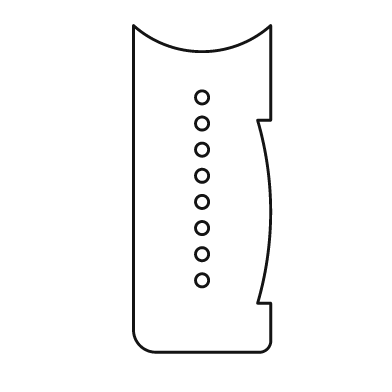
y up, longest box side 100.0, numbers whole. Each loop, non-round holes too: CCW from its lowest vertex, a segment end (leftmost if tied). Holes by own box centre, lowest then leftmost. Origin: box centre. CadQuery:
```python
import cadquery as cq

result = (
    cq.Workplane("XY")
    .moveTo(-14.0, -50.0)
    .lineTo(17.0, -50.0)
    .threePointArc((20.0, -49.0), (21.0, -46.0))
    .lineTo(21.0, -35.0)
    .lineTo(17.0, -35.0)
    .threePointArc((21.0, -7.0), (17.0, 21.0))
    .lineTo(21.0, 21.0)
    .lineTo(21.0, 50.0)
    .threePointArc((0.0, 42.0), (-21.0, 50.0))
    .lineTo(-21.0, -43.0)
    .threePointArc((-19.0, -48.0), (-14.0, -50.0))
    .close()
    .moveTo(0.0, -28.0)
    .circle(2.0)
    .moveTo(0.0, -20.0)
    .circle(2.0)
    .moveTo(0.0, -12.0)
    .circle(2.0)
    .moveTo(0.0, -4.0)
    .circle(2.0)
    .moveTo(0.0, 4.0)
    .circle(2.0)
    .moveTo(0.0, 12.0)
    .circle(2.0)
    .moveTo(0.0, 20.0)
    .circle(2.0)
    .moveTo(0.0, 28.0)
    .circle(2.0)
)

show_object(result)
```